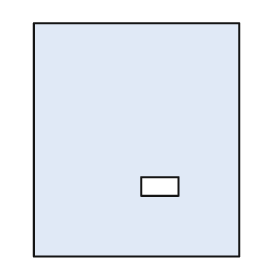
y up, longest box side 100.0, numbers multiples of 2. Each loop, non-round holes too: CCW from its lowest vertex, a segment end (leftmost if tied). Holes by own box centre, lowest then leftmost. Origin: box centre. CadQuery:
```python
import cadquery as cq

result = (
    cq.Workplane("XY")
    .moveTo(-44.0, -50.0)
    .lineTo(44.0, -50.0)
    .lineTo(44.0, 50.0)
    .lineTo(-44.0, 50.0)
    .close()
    .moveTo(2.0, -24.0)
    .lineTo(18.0, -24.0)
    .lineTo(18.0, -16.0)
    .lineTo(2.0, -16.0)
    .close()
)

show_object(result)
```